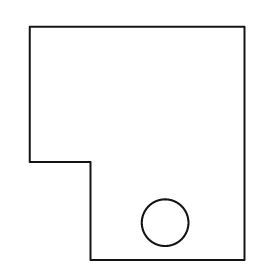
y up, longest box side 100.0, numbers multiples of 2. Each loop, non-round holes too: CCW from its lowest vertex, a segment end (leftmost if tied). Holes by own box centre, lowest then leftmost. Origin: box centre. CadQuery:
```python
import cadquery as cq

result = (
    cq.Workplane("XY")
    .moveTo(-20.0, -50.0)
    .lineTo(46.0, -50.0)
    .lineTo(46.0, 50.0)
    .lineTo(-46.0, 50.0)
    .lineTo(-46.0, -8.0)
    .lineTo(-20.0, -8.0)
    .close()
    .moveTo(12.0, -34.0)
    .circle(10.0)
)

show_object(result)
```